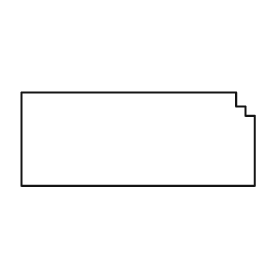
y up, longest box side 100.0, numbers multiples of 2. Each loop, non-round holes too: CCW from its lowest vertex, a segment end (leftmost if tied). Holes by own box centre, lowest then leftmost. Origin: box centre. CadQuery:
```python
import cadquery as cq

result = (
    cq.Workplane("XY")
    .moveTo(-50.0, -20.0)
    .lineTo(50.0, -20.0)
    .lineTo(50.0, 10.0)
    .lineTo(46.0, 10.0)
    .lineTo(46.0, 14.0)
    .lineTo(42.0, 14.0)
    .lineTo(42.0, 20.0)
    .lineTo(-50.0, 20.0)
    .close()
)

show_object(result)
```